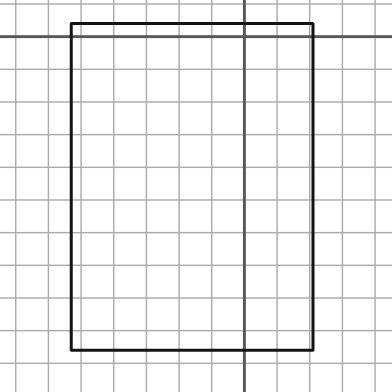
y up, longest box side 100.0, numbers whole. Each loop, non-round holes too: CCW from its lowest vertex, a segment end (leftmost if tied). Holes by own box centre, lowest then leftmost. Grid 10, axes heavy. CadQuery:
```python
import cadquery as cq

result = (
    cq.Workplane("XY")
    .moveTo(-53.0, -96.0)
    .lineTo(21.0, -96.0)
    .lineTo(21.0, 4.0)
    .lineTo(-53.0, 4.0)
    .close()
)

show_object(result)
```